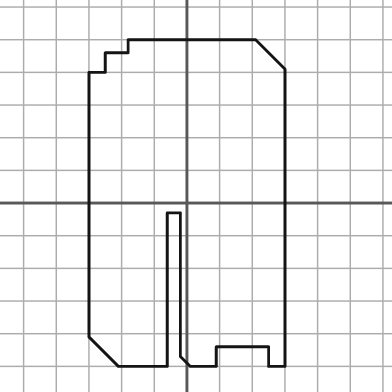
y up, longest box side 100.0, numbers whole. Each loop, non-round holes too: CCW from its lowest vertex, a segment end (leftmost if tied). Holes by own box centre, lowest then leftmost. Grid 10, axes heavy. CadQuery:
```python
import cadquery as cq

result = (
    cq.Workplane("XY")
    .moveTo(-21.0, -50.0)
    .lineTo(-6.0, -50.0)
    .lineTo(-6.0, -3.0)
    .lineTo(-2.0, -3.0)
    .lineTo(-2.0, -47.0)
    .lineTo(1.0, -50.0)
    .lineTo(9.0, -50.0)
    .lineTo(9.0, -44.0)
    .lineTo(25.0, -44.0)
    .lineTo(25.0, -50.0)
    .lineTo(30.0, -50.0)
    .lineTo(30.0, 41.0)
    .lineTo(21.0, 50.0)
    .lineTo(-18.0, 50.0)
    .lineTo(-18.0, 46.0)
    .lineTo(-25.0, 46.0)
    .lineTo(-25.0, 40.0)
    .lineTo(-30.0, 40.0)
    .lineTo(-30.0, -41.0)
    .close()
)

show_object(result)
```